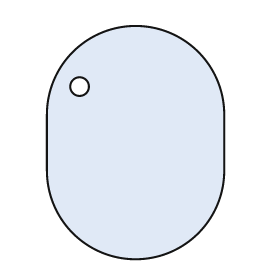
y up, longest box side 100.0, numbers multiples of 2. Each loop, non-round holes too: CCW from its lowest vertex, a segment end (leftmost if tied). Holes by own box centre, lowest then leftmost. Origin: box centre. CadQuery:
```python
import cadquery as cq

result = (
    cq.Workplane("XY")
    .moveTo(-38.0, -12.0)
    .threePointArc((0.0, -50.0), (38.0, -12.0))
    .lineTo(38.0, 12.0)
    .threePointArc((0.0, 50.0), (-38.0, 12.0))
    .close()
    .moveTo(-24.0, 24.0)
    .circle(4.0)
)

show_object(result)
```